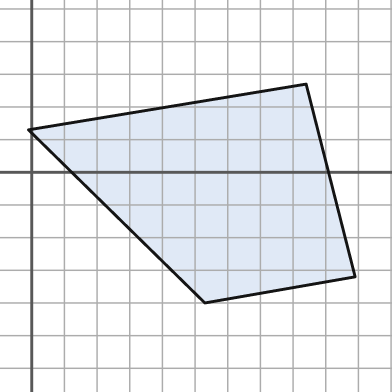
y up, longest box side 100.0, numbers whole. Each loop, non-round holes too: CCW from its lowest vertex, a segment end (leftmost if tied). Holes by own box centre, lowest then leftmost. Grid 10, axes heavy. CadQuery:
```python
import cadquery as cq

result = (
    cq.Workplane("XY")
    .moveTo(53.0, -40.0)
    .lineTo(99.0, -32.0)
    .lineTo(84.0, 27.0)
    .lineTo(-1.0, 13.0)
    .close()
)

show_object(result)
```